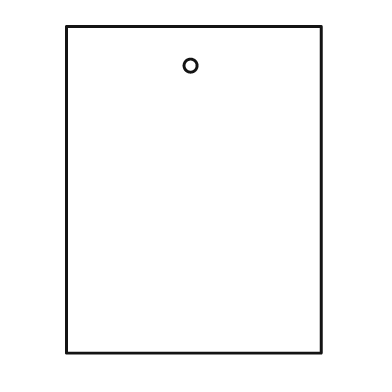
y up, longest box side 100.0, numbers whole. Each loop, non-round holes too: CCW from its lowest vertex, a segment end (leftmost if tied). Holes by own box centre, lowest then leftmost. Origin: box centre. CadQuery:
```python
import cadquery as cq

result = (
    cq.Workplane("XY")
    .moveTo(-39.0, -50.0)
    .lineTo(39.0, -50.0)
    .lineTo(39.0, 50.0)
    .lineTo(-39.0, 50.0)
    .close()
    .moveTo(-1.0, 38.0)
    .circle(2.0)
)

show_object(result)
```